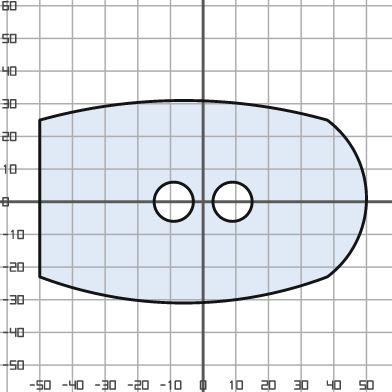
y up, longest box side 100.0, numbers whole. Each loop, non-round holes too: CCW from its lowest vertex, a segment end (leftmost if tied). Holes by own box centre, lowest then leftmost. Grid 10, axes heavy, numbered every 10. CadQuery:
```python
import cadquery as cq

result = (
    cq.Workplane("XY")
    .moveTo(-50.0, -23.0)
    .threePointArc((-6.0, -31.0), (38.0, -23.0))
    .threePointArc((50.0, 1.0), (38.0, 25.0))
    .threePointArc((-6.0, 31.0), (-50.0, 25.0))
    .close()
    .moveTo(-9.0, 0.0)
    .circle(6.0)
    .moveTo(9.0, 0.0)
    .circle(6.0)
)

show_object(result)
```